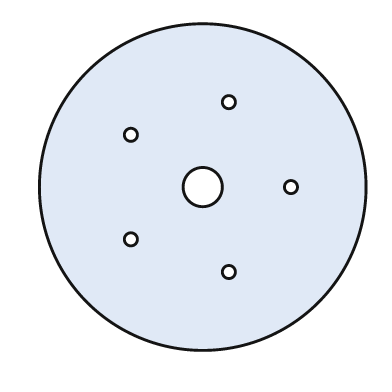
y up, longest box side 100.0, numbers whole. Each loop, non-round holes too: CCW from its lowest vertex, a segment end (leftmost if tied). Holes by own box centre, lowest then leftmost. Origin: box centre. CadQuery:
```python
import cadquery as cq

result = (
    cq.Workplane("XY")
    .moveTo(0.0, 0.0)
    .circle(50.0)
    .moveTo(8.0, -26.0)
    .circle(2.0)
    .moveTo(-22.0, -16.0)
    .circle(2.0)
    .moveTo(0.0, 0.0)
    .circle(6.0)
    .moveTo(27.0, 0.0)
    .circle(2.0)
    .moveTo(-22.0, 16.0)
    .circle(2.0)
    .moveTo(8.0, 26.0)
    .circle(2.0)
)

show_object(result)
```